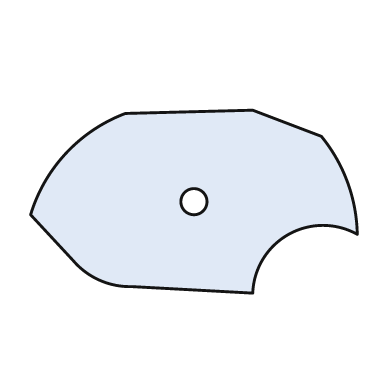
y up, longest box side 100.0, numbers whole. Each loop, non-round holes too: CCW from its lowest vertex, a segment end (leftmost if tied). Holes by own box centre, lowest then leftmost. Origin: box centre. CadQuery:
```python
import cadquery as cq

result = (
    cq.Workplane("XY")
    .moveTo(18.0, -28.0)
    .threePointArc((29.0, -10.0), (50.0, -10.0))
    .threePointArc((47.0, 6.0), (39.0, 20.0))
    .lineTo(18.0, 28.0)
    .lineTo(-21.0, 27.0)
    .threePointArc((-39.0, 15.0), (-50.0, -4.0))
    .lineTo(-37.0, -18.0)
    .threePointArc((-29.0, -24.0), (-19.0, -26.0))
    .close()
    .moveTo(0.0, 0.0)
    .circle(4.0)
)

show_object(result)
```